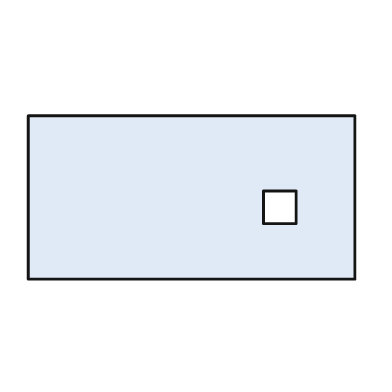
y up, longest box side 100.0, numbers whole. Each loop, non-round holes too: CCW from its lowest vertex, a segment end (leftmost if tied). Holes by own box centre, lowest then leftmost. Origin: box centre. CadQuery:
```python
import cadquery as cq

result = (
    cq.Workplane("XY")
    .moveTo(-50.0, -25.0)
    .lineTo(50.0, -25.0)
    .lineTo(50.0, 25.0)
    .lineTo(-50.0, 25.0)
    .close()
    .moveTo(22.0, -8.0)
    .lineTo(32.0, -8.0)
    .lineTo(32.0, 2.0)
    .lineTo(22.0, 2.0)
    .close()
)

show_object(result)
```